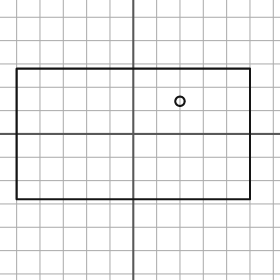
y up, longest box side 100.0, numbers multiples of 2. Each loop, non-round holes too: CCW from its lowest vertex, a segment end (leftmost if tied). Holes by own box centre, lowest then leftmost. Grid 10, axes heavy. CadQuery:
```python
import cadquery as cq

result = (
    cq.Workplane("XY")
    .moveTo(-50.0, -28.0)
    .lineTo(50.0, -28.0)
    .lineTo(50.0, 28.0)
    .lineTo(-50.0, 28.0)
    .close()
    .moveTo(20.0, 14.0)
    .circle(2.0)
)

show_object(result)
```